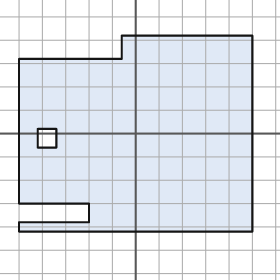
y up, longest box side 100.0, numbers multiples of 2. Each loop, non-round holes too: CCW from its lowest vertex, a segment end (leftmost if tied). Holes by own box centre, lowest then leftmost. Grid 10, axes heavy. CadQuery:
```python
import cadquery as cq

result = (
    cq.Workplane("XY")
    .moveTo(-50.0, -42.0)
    .lineTo(50.0, -42.0)
    .lineTo(50.0, 42.0)
    .lineTo(-6.0, 42.0)
    .lineTo(-6.0, 32.0)
    .lineTo(-50.0, 32.0)
    .lineTo(-50.0, -30.0)
    .lineTo(-20.0, -30.0)
    .lineTo(-20.0, -38.0)
    .lineTo(-50.0, -38.0)
    .close()
    .moveTo(-42.0, -6.0)
    .lineTo(-34.0, -6.0)
    .lineTo(-34.0, 2.0)
    .lineTo(-42.0, 2.0)
    .close()
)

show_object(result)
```